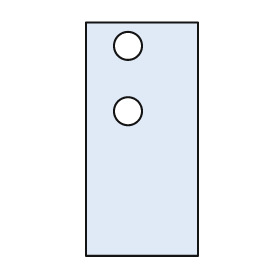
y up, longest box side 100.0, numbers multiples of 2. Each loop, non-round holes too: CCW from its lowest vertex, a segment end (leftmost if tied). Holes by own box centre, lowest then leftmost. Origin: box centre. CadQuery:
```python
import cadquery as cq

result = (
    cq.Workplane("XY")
    .moveTo(-24.0, -50.0)
    .lineTo(24.0, -50.0)
    .lineTo(24.0, 50.0)
    .lineTo(-24.0, 50.0)
    .close()
    .moveTo(-6.0, 12.0)
    .circle(6.0)
    .moveTo(-6.0, 40.0)
    .circle(6.0)
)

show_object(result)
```